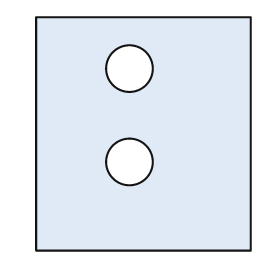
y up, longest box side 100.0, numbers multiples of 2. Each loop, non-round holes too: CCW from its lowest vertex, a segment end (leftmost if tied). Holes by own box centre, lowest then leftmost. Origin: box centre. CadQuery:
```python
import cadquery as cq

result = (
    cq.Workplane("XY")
    .moveTo(-46.0, -50.0)
    .lineTo(46.0, -50.0)
    .lineTo(46.0, 50.0)
    .lineTo(-46.0, 50.0)
    .close()
    .moveTo(-6.0, -12.0)
    .circle(10.0)
    .moveTo(-6.0, 28.0)
    .circle(10.0)
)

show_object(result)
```